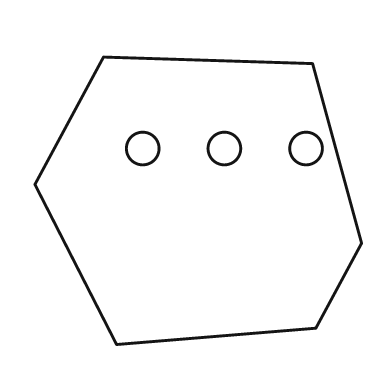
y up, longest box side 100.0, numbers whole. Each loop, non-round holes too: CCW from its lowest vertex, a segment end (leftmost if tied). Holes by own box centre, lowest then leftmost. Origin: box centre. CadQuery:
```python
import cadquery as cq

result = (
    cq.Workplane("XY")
    .moveTo(-25.0, -44.0)
    .lineTo(36.0, -39.0)
    .lineTo(50.0, -13.0)
    .lineTo(35.0, 42.0)
    .lineTo(-29.0, 44.0)
    .lineTo(-50.0, 5.0)
    .close()
    .moveTo(-17.0, 16.0)
    .circle(5.0)
    .moveTo(8.0, 16.0)
    .circle(5.0)
    .moveTo(33.0, 16.0)
    .circle(5.0)
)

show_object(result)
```